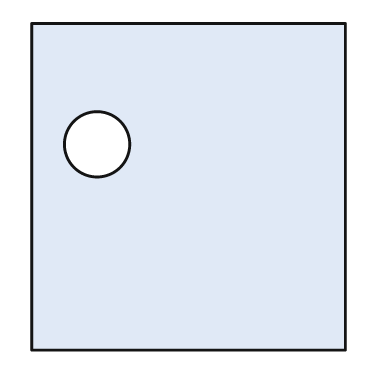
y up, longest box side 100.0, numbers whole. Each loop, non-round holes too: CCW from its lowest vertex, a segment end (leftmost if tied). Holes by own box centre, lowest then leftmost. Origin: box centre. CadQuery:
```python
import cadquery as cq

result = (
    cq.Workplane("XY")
    .moveTo(-48.0, -50.0)
    .lineTo(48.0, -50.0)
    .lineTo(48.0, 50.0)
    .lineTo(-48.0, 50.0)
    .close()
    .moveTo(-28.0, 13.0)
    .circle(10.0)
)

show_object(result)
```